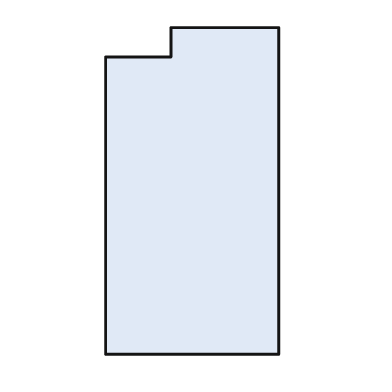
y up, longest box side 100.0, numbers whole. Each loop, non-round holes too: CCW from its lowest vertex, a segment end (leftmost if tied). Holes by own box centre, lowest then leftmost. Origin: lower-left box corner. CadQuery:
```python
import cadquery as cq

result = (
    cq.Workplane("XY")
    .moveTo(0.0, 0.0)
    .lineTo(53.0, 0.0)
    .lineTo(53.0, 100.0)
    .lineTo(20.0, 100.0)
    .lineTo(20.0, 91.0)
    .lineTo(0.0, 91.0)
    .close()
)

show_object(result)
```